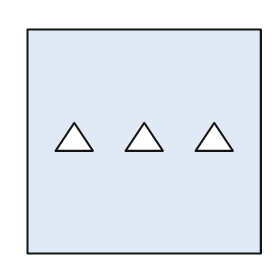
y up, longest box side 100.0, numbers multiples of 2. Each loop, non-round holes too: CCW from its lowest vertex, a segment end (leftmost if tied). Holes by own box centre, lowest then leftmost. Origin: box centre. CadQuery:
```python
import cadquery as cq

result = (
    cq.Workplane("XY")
    .moveTo(-50.0, -48.0)
    .lineTo(50.0, -48.0)
    .lineTo(50.0, 48.0)
    .lineTo(-50.0, 48.0)
    .close()
    .moveTo(-38.0, -4.0)
    .lineTo(-22.0, -4.0)
    .lineTo(-30.0, 8.0)
    .close()
    .moveTo(-8.0, -4.0)
    .lineTo(8.0, -4.0)
    .lineTo(0.0, 8.0)
    .close()
    .moveTo(22.0, -4.0)
    .lineTo(38.0, -4.0)
    .lineTo(30.0, 8.0)
    .close()
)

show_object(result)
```